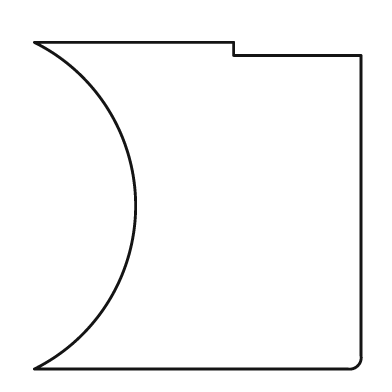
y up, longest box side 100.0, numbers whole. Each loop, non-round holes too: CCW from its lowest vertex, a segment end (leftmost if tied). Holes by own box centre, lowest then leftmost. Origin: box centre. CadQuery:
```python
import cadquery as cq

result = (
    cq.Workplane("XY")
    .moveTo(-50.0, -50.0)
    .lineTo(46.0, -50.0)
    .threePointArc((49.0, -49.0), (50.0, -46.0))
    .lineTo(50.0, 46.0)
    .lineTo(11.0, 46.0)
    .lineTo(11.0, 50.0)
    .lineTo(-50.0, 50.0)
    .threePointArc((-19.0, 0.0), (-50.0, -50.0))
    .close()
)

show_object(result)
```